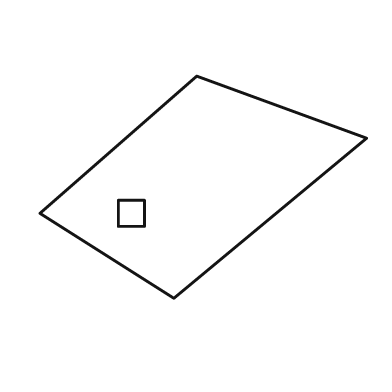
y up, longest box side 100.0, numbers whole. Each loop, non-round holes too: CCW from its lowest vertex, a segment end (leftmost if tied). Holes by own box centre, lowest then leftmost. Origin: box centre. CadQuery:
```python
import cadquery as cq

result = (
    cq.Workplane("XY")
    .moveTo(-9.0, -34.0)
    .lineTo(50.0, 15.0)
    .lineTo(-2.0, 34.0)
    .lineTo(-50.0, -8.0)
    .close()
    .moveTo(-26.0, -12.0)
    .lineTo(-18.0, -12.0)
    .lineTo(-18.0, -4.0)
    .lineTo(-26.0, -4.0)
    .close()
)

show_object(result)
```